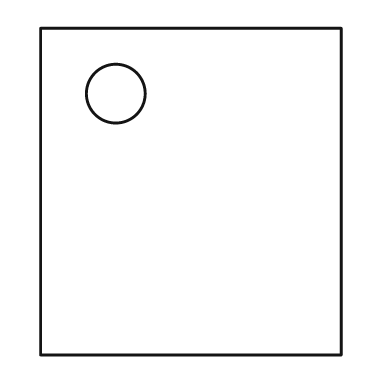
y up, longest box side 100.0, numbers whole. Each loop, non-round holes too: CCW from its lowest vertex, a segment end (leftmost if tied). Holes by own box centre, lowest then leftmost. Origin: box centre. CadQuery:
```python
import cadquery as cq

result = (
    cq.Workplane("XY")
    .moveTo(-46.0, -50.0)
    .lineTo(46.0, -50.0)
    .lineTo(46.0, 50.0)
    .lineTo(-46.0, 50.0)
    .close()
    .moveTo(-23.0, 30.0)
    .circle(9.0)
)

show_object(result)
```